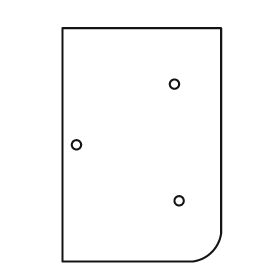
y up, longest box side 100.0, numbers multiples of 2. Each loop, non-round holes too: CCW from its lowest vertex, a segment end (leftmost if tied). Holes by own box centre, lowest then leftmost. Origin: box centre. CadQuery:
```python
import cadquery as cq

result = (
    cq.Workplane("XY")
    .moveTo(-34.0, -50.0)
    .lineTo(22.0, -50.0)
    .threePointArc((30.0, -46.0), (34.0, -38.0))
    .lineTo(34.0, 50.0)
    .lineTo(-34.0, 50.0)
    .close()
    .moveTo(16.0, -24.0)
    .circle(2.0)
    .moveTo(-28.0, 0.0)
    .circle(2.0)
    .moveTo(14.0, 26.0)
    .circle(2.0)
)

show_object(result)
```